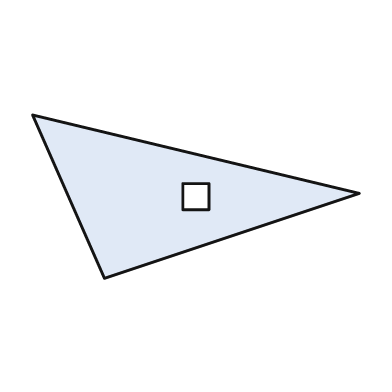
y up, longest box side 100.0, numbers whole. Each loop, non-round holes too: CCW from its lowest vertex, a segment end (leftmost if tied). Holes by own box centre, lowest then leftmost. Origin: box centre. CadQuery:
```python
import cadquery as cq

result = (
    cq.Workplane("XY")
    .moveTo(-28.0, -25.0)
    .lineTo(50.0, 1.0)
    .lineTo(-50.0, 25.0)
    .close()
    .moveTo(-4.0, -4.0)
    .lineTo(4.0, -4.0)
    .lineTo(4.0, 4.0)
    .lineTo(-4.0, 4.0)
    .close()
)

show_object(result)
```